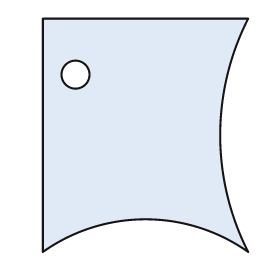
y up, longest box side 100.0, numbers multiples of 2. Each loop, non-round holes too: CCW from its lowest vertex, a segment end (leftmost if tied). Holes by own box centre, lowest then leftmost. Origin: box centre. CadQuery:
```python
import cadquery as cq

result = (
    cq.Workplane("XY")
    .moveTo(-44.0, -50.0)
    .threePointArc((0.0, -36.0), (44.0, -50.0))
    .threePointArc((32.0, 0.0), (44.0, 50.0))
    .lineTo(-44.0, 50.0)
    .close()
    .moveTo(-30.0, 26.0)
    .circle(6.0)
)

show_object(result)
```